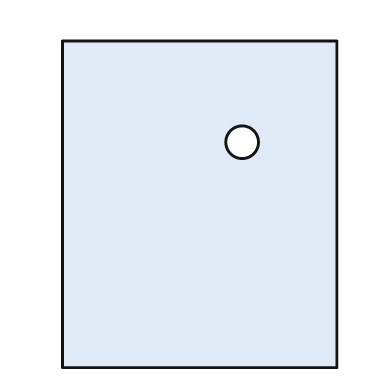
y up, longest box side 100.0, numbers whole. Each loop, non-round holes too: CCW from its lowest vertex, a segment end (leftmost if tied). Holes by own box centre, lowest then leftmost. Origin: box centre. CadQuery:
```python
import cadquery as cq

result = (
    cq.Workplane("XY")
    .moveTo(-42.0, -50.0)
    .lineTo(42.0, -50.0)
    .lineTo(42.0, 50.0)
    .lineTo(-42.0, 50.0)
    .close()
    .moveTo(13.0, 19.0)
    .circle(5.0)
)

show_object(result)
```